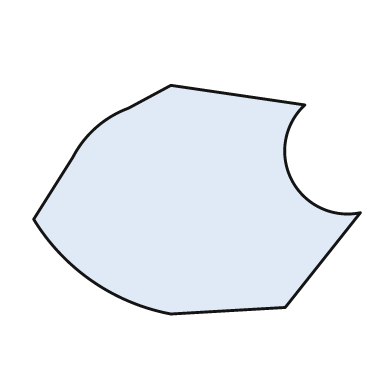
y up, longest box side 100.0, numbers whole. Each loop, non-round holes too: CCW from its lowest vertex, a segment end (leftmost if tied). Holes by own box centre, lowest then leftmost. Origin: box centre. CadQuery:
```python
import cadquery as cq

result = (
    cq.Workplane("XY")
    .moveTo(-8.0, -35.0)
    .lineTo(27.0, -33.0)
    .lineTo(50.0, -4.0)
    .threePointArc((29.0, 6.0), (33.0, 29.0))
    .lineTo(-8.0, 35.0)
    .lineTo(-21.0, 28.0)
    .threePointArc((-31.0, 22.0), (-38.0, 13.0))
    .lineTo(-50.0, -6.0)
    .threePointArc((-32.0, -25.0), (-8.0, -35.0))
    .close()
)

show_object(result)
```